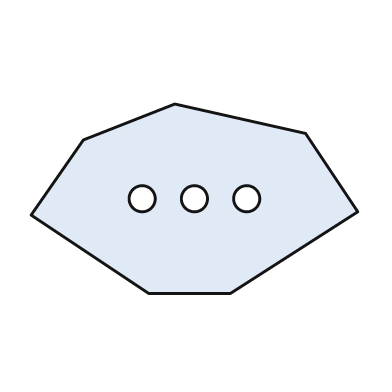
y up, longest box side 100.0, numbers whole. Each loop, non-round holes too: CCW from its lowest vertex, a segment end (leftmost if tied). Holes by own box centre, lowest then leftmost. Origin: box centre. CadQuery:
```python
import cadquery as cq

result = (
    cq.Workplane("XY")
    .moveTo(-14.0, -29.0)
    .lineTo(11.0, -29.0)
    .lineTo(50.0, -4.0)
    .lineTo(34.0, 20.0)
    .lineTo(-6.0, 29.0)
    .lineTo(-34.0, 18.0)
    .lineTo(-50.0, -5.0)
    .close()
    .moveTo(-16.0, 0.0)
    .circle(4.0)
    .moveTo(0.0, 0.0)
    .circle(4.0)
    .moveTo(16.0, 0.0)
    .circle(4.0)
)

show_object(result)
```